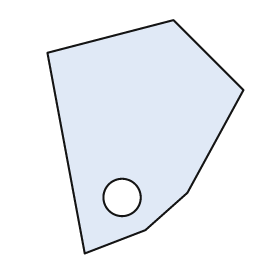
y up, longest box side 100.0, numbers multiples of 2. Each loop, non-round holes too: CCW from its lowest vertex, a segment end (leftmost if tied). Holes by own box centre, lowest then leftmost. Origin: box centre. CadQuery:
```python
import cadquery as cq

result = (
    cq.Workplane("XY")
    .moveTo(-26.0, -50.0)
    .lineTo(0.0, -40.0)
    .lineTo(18.0, -24.0)
    .lineTo(42.0, 20.0)
    .lineTo(12.0, 50.0)
    .lineTo(-42.0, 36.0)
    .close()
    .moveTo(-10.0, -26.0)
    .circle(8.0)
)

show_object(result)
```